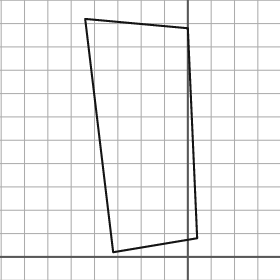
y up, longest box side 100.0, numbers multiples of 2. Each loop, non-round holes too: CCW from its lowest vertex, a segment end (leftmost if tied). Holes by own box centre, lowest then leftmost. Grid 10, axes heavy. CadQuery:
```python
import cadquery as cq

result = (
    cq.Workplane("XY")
    .moveTo(-32.0, 2.0)
    .lineTo(4.0, 8.0)
    .lineTo(0.0, 98.0)
    .lineTo(-44.0, 102.0)
    .close()
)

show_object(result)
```